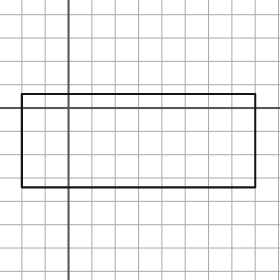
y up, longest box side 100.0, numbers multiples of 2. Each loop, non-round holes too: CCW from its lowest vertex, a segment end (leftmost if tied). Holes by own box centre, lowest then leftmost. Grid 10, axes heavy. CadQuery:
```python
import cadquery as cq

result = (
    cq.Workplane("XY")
    .moveTo(-20.0, -34.0)
    .lineTo(80.0, -34.0)
    .lineTo(80.0, 6.0)
    .lineTo(-20.0, 6.0)
    .close()
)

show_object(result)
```